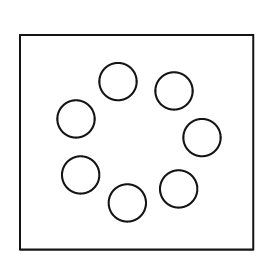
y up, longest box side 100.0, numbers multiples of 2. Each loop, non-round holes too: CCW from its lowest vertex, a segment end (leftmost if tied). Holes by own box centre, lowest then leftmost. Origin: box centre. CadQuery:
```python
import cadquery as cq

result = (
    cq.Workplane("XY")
    .moveTo(-50.0, -46.0)
    .lineTo(50.0, -46.0)
    .lineTo(50.0, 46.0)
    .lineTo(-50.0, 46.0)
    .close()
    .moveTo(-4.0, -26.0)
    .circle(8.0)
    .moveTo(18.0, -20.0)
    .circle(8.0)
    .moveTo(-24.0, -14.0)
    .circle(8.0)
    .moveTo(28.0, 2.0)
    .circle(8.0)
    .moveTo(-26.0, 10.0)
    .circle(8.0)
    .moveTo(16.0, 22.0)
    .circle(8.0)
    .moveTo(-8.0, 26.0)
    .circle(8.0)
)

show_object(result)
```